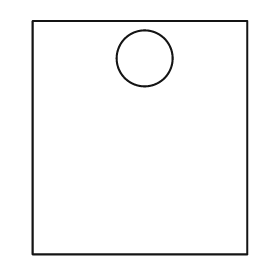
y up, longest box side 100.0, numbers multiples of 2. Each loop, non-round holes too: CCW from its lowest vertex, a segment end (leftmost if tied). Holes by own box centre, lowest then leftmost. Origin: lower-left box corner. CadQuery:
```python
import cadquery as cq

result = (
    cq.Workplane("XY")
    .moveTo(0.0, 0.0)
    .lineTo(92.0, 0.0)
    .lineTo(92.0, 100.0)
    .lineTo(0.0, 100.0)
    .close()
    .moveTo(48.0, 84.0)
    .circle(12.0)
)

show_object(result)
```